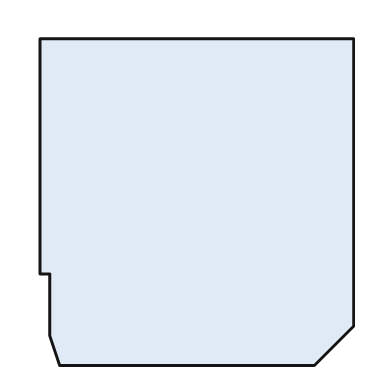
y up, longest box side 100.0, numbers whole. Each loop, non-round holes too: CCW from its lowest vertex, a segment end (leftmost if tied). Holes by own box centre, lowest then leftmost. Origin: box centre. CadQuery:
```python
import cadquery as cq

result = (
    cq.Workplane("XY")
    .moveTo(-42.0, -50.0)
    .lineTo(36.0, -50.0)
    .lineTo(48.0, -38.0)
    .lineTo(48.0, 50.0)
    .lineTo(-48.0, 50.0)
    .lineTo(-48.0, -22.0)
    .lineTo(-45.0, -22.0)
    .lineTo(-45.0, -41.0)
    .close()
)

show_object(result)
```